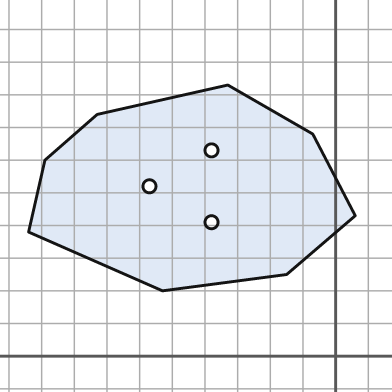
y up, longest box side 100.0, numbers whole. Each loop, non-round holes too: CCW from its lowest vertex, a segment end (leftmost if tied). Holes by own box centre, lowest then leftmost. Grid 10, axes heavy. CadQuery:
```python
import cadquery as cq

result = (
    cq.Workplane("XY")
    .moveTo(-53.0, 20.0)
    .lineTo(-15.0, 25.0)
    .lineTo(6.0, 43.0)
    .lineTo(-7.0, 68.0)
    .lineTo(-33.0, 83.0)
    .lineTo(-73.0, 74.0)
    .lineTo(-89.0, 60.0)
    .lineTo(-94.0, 38.0)
    .close()
    .moveTo(-38.0, 41.0)
    .circle(2.0)
    .moveTo(-57.0, 52.0)
    .circle(2.0)
    .moveTo(-38.0, 63.0)
    .circle(2.0)
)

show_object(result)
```